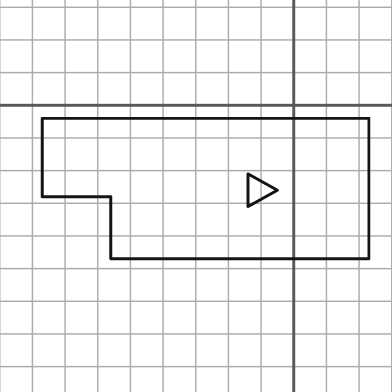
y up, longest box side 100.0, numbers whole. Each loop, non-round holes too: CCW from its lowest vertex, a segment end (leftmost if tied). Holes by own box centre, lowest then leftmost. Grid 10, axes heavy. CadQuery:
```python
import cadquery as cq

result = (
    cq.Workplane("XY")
    .moveTo(-56.0, -47.0)
    .lineTo(23.0, -47.0)
    .lineTo(23.0, -4.0)
    .lineTo(-77.0, -4.0)
    .lineTo(-77.0, -28.0)
    .lineTo(-56.0, -28.0)
    .close()
    .moveTo(-14.0, -31.0)
    .lineTo(-5.0, -26.0)
    .lineTo(-14.0, -21.0)
    .close()
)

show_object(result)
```